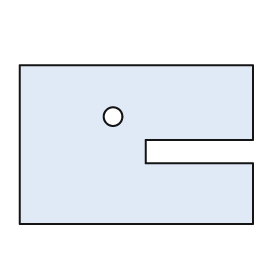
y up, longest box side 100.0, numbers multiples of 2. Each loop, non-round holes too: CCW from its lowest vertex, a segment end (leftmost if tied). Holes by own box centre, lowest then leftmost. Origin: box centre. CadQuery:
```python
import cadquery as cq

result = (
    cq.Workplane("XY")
    .moveTo(-50.0, -34.0)
    .lineTo(50.0, -34.0)
    .lineTo(50.0, -8.0)
    .lineTo(4.0, -8.0)
    .lineTo(4.0, 2.0)
    .lineTo(50.0, 2.0)
    .lineTo(50.0, 34.0)
    .lineTo(-50.0, 34.0)
    .close()
    .moveTo(-10.0, 12.0)
    .circle(4.0)
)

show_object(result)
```